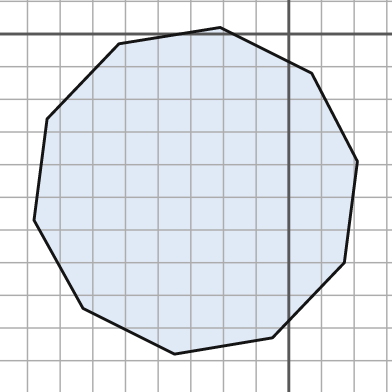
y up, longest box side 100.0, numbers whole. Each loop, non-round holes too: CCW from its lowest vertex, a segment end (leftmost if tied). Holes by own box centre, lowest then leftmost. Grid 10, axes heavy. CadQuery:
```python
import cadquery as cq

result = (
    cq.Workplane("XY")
    .moveTo(-35.0, -98.0)
    .lineTo(-5.0, -93.0)
    .lineTo(17.0, -70.0)
    .lineTo(21.0, -39.0)
    .lineTo(7.0, -12.0)
    .lineTo(-21.0, 2.0)
    .lineTo(-52.0, -3.0)
    .lineTo(-74.0, -26.0)
    .lineTo(-78.0, -57.0)
    .lineTo(-63.0, -84.0)
    .close()
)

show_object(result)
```